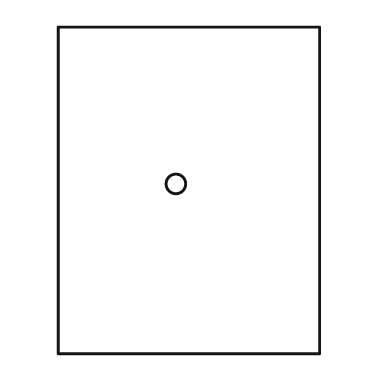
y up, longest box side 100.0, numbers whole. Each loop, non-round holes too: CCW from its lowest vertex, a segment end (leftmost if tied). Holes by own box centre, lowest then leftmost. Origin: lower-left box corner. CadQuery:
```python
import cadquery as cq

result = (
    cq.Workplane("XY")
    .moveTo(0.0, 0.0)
    .lineTo(80.0, 0.0)
    .lineTo(80.0, 100.0)
    .lineTo(0.0, 100.0)
    .close()
    .moveTo(36.0, 52.0)
    .circle(3.0)
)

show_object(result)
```